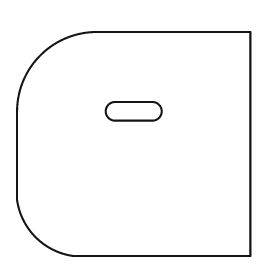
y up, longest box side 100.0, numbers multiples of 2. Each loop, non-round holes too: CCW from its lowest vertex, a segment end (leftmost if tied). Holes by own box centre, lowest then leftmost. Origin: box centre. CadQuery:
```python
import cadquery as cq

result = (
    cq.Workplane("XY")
    .moveTo(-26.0, -48.0)
    .lineTo(50.0, -48.0)
    .lineTo(50.0, 48.0)
    .lineTo(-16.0, 48.0)
    .threePointArc((-40.0, 38.0), (-50.0, 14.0))
    .lineTo(-50.0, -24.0)
    .threePointArc((-42.0, -40.0), (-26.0, -48.0))
    .close()
    .moveTo(-8.0, 10.0)
    .lineTo(8.0, 10.0)
    .threePointArc((12.0, 14.0), (8.0, 18.0))
    .lineTo(-8.0, 18.0)
    .threePointArc((-12.0, 14.0), (-8.0, 10.0))
    .close()
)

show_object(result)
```